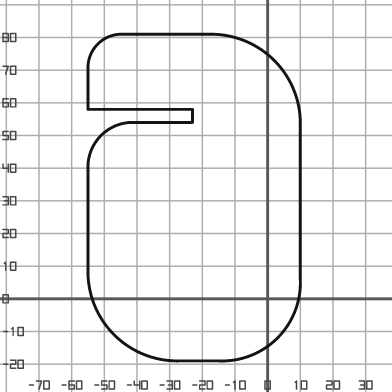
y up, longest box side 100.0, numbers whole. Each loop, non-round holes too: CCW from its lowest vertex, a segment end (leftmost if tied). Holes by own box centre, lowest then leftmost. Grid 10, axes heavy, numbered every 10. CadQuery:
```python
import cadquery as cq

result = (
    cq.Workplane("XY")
    .moveTo(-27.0, -19.0)
    .lineTo(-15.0, -19.0)
    .threePointArc((3.0, -12.0), (10.0, 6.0))
    .lineTo(10.0, 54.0)
    .threePointArc((2.0, 73.0), (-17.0, 81.0))
    .lineTo(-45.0, 81.0)
    .threePointArc((-52.0, 78.0), (-55.0, 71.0))
    .lineTo(-55.0, 58.0)
    .lineTo(-23.0, 58.0)
    .lineTo(-23.0, 54.0)
    .lineTo(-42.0, 54.0)
    .threePointArc((-51.0, 50.0), (-55.0, 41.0))
    .lineTo(-55.0, 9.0)
    .threePointArc((-47.0, -11.0), (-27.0, -19.0))
    .close()
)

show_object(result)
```